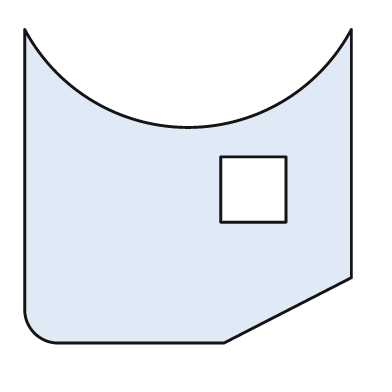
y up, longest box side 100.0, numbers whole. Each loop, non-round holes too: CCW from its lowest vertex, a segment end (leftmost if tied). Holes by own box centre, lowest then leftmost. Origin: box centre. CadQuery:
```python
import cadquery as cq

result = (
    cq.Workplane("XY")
    .moveTo(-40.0, -48.0)
    .lineTo(11.0, -48.0)
    .lineTo(50.0, -28.0)
    .lineTo(50.0, 48.0)
    .threePointArc((0.0, 18.0), (-50.0, 48.0))
    .lineTo(-50.0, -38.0)
    .threePointArc((-47.0, -45.0), (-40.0, -48.0))
    .close()
    .moveTo(10.0, -11.0)
    .lineTo(30.0, -11.0)
    .lineTo(30.0, 9.0)
    .lineTo(10.0, 9.0)
    .close()
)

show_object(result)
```